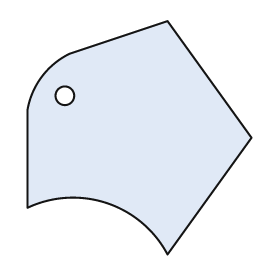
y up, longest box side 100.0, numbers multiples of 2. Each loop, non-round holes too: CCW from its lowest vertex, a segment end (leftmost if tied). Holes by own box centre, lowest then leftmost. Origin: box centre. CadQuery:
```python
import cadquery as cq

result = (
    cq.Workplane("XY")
    .moveTo(12.0, -50.0)
    .lineTo(48.0, 0.0)
    .lineTo(12.0, 50.0)
    .lineTo(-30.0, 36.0)
    .threePointArc((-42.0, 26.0), (-48.0, 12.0))
    .lineTo(-48.0, -30.0)
    .threePointArc((-14.0, -28.0), (12.0, -50.0))
    .close()
    .moveTo(-32.0, 18.0)
    .circle(4.0)
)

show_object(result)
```